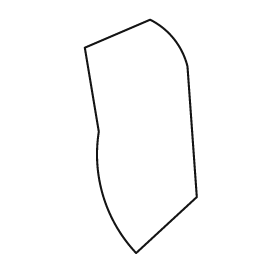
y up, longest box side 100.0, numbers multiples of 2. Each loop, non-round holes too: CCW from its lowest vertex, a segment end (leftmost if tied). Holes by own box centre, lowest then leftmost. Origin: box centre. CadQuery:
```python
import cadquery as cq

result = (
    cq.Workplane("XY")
    .moveTo(-2.0, -50.0)
    .lineTo(24.0, -26.0)
    .lineTo(20.0, 30.0)
    .threePointArc((14.0, 42.0), (4.0, 50.0))
    .lineTo(-24.0, 38.0)
    .lineTo(-18.0, 2.0)
    .threePointArc((-16.0, -26.0), (-2.0, -50.0))
    .close()
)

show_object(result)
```